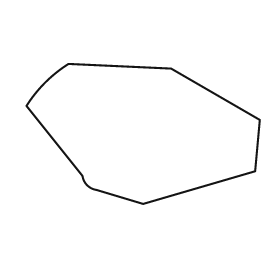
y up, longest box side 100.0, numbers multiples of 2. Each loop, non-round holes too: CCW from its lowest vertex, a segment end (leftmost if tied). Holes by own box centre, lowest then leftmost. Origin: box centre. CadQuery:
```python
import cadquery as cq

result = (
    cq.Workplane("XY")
    .moveTo(0.0, -30.0)
    .lineTo(48.0, -16.0)
    .lineTo(50.0, 6.0)
    .lineTo(12.0, 28.0)
    .lineTo(-32.0, 30.0)
    .threePointArc((-42.0, 22.0), (-50.0, 12.0))
    .lineTo(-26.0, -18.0)
    .threePointArc((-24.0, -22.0), (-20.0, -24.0))
    .close()
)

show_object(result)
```